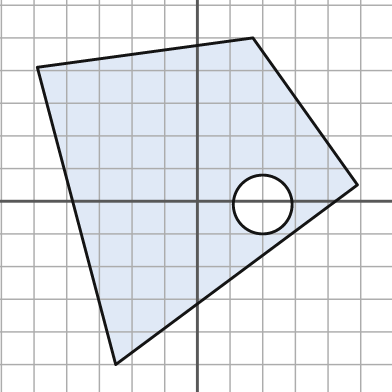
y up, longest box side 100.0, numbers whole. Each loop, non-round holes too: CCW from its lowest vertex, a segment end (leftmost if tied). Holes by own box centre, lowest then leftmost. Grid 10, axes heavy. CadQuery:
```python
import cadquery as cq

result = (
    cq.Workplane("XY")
    .moveTo(-25.0, -50.0)
    .lineTo(49.0, 5.0)
    .lineTo(17.0, 50.0)
    .lineTo(-49.0, 41.0)
    .close()
    .moveTo(20.0, -1.0)
    .circle(9.0)
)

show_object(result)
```